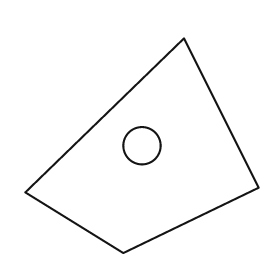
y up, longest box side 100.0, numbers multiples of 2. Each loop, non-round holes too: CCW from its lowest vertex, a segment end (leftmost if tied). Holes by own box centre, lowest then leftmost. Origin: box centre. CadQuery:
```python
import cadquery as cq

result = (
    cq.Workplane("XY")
    .moveTo(-8.0, -46.0)
    .lineTo(50.0, -18.0)
    .lineTo(18.0, 46.0)
    .lineTo(-50.0, -20.0)
    .close()
    .moveTo(0.0, 0.0)
    .circle(8.0)
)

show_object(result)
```